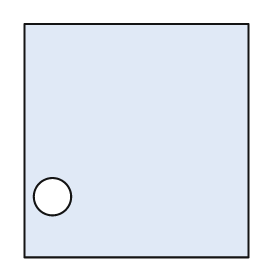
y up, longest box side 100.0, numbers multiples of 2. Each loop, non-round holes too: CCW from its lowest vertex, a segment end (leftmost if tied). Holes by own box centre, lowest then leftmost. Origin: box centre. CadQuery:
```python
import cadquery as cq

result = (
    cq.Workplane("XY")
    .moveTo(-48.0, -50.0)
    .lineTo(48.0, -50.0)
    .lineTo(48.0, 50.0)
    .lineTo(-48.0, 50.0)
    .close()
    .moveTo(-36.0, -24.0)
    .circle(8.0)
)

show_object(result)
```